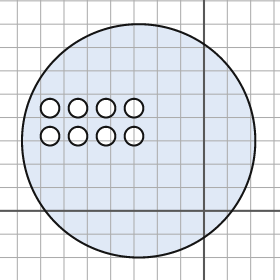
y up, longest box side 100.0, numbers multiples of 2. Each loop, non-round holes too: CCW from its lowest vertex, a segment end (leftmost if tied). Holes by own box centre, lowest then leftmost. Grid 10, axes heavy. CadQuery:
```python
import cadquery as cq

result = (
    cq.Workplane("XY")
    .moveTo(-28.0, 30.0)
    .circle(50.0)
    .moveTo(-66.0, 32.0)
    .circle(4.0)
    .moveTo(-54.0, 32.0)
    .circle(4.0)
    .moveTo(-42.0, 32.0)
    .circle(4.0)
    .moveTo(-30.0, 32.0)
    .circle(4.0)
    .moveTo(-66.0, 44.0)
    .circle(4.0)
    .moveTo(-54.0, 44.0)
    .circle(4.0)
    .moveTo(-42.0, 44.0)
    .circle(4.0)
    .moveTo(-30.0, 44.0)
    .circle(4.0)
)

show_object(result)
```